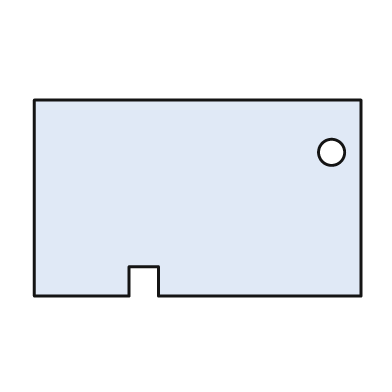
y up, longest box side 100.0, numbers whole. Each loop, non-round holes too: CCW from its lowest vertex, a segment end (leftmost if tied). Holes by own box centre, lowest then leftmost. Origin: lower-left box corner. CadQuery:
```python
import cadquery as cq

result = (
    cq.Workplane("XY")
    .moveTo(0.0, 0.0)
    .lineTo(29.0, 0.0)
    .lineTo(29.0, 9.0)
    .lineTo(38.0, 9.0)
    .lineTo(38.0, 0.0)
    .lineTo(100.0, 0.0)
    .lineTo(100.0, 60.0)
    .lineTo(0.0, 60.0)
    .close()
    .moveTo(91.0, 44.0)
    .circle(4.0)
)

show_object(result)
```